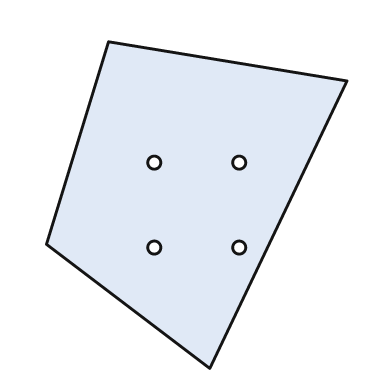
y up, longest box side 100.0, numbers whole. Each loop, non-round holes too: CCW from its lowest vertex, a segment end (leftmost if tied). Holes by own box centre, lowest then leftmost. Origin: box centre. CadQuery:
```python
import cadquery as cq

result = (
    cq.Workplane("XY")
    .moveTo(4.0, -50.0)
    .lineTo(46.0, 38.0)
    .lineTo(-27.0, 50.0)
    .lineTo(-46.0, -12.0)
    .close()
    .moveTo(-13.0, -13.0)
    .circle(2.0)
    .moveTo(13.0, -13.0)
    .circle(2.0)
    .moveTo(-13.0, 13.0)
    .circle(2.0)
    .moveTo(13.0, 13.0)
    .circle(2.0)
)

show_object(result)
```